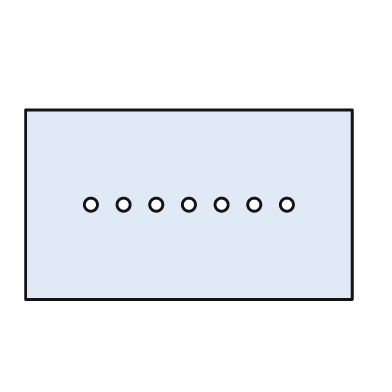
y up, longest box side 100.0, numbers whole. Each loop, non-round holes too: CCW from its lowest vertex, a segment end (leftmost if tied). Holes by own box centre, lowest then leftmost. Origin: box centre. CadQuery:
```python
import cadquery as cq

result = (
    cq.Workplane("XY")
    .moveTo(-50.0, -29.0)
    .lineTo(50.0, -29.0)
    .lineTo(50.0, 29.0)
    .lineTo(-50.0, 29.0)
    .close()
    .moveTo(-30.0, 0.0)
    .circle(2.0)
    .moveTo(-20.0, 0.0)
    .circle(2.0)
    .moveTo(-10.0, 0.0)
    .circle(2.0)
    .moveTo(0.0, 0.0)
    .circle(2.0)
    .moveTo(10.0, 0.0)
    .circle(2.0)
    .moveTo(20.0, 0.0)
    .circle(2.0)
    .moveTo(30.0, 0.0)
    .circle(2.0)
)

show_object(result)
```